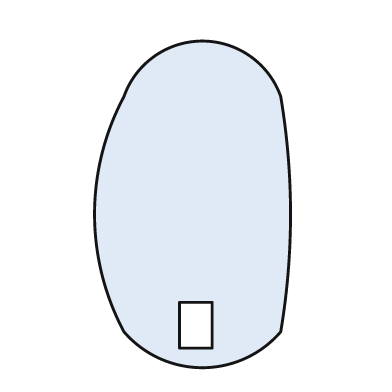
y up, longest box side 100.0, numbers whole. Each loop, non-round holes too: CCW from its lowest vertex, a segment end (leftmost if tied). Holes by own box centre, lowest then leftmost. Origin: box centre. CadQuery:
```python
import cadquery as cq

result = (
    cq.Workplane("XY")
    .moveTo(-21.0, -39.0)
    .threePointArc((3.0, -50.0), (27.0, -39.0))
    .threePointArc((30.0, -3.0), (27.0, 33.0))
    .threePointArc((3.0, 50.0), (-21.0, 33.0))
    .threePointArc((-30.0, -3.0), (-21.0, -39.0))
    .close()
    .moveTo(-4.0, -44.0)
    .lineTo(6.0, -44.0)
    .lineTo(6.0, -30.0)
    .lineTo(-4.0, -30.0)
    .close()
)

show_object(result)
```